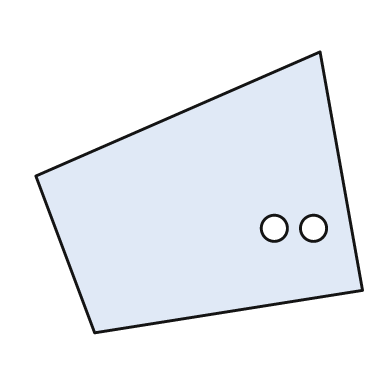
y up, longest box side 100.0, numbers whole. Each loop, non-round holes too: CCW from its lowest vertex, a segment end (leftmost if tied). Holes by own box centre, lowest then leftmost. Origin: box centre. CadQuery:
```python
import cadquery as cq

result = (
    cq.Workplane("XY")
    .moveTo(-32.0, -43.0)
    .lineTo(50.0, -30.0)
    .lineTo(37.0, 43.0)
    .lineTo(-50.0, 5.0)
    .close()
    .moveTo(23.0, -11.0)
    .circle(4.0)
    .moveTo(35.0, -11.0)
    .circle(4.0)
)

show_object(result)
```